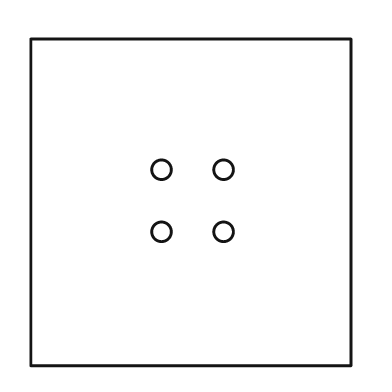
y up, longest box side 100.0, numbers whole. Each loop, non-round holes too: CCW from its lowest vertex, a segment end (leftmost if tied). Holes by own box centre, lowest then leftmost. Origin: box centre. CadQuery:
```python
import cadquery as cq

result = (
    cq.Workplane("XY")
    .moveTo(-49.0, -50.0)
    .lineTo(49.0, -50.0)
    .lineTo(49.0, 50.0)
    .lineTo(-49.0, 50.0)
    .close()
    .moveTo(-9.0, -9.0)
    .circle(3.0)
    .moveTo(10.0, -9.0)
    .circle(3.0)
    .moveTo(-9.0, 10.0)
    .circle(3.0)
    .moveTo(10.0, 10.0)
    .circle(3.0)
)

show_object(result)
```